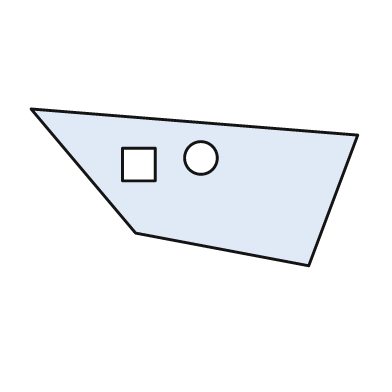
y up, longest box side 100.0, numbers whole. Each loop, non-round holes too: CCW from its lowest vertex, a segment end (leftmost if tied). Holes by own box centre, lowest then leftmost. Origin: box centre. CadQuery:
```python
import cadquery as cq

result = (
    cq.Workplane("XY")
    .moveTo(35.0, -24.0)
    .lineTo(50.0, 16.0)
    .lineTo(-50.0, 24.0)
    .lineTo(-18.0, -14.0)
    .close()
    .moveTo(-22.0, 2.0)
    .lineTo(-12.0, 2.0)
    .lineTo(-12.0, 12.0)
    .lineTo(-22.0, 12.0)
    .close()
    .moveTo(2.0, 9.0)
    .circle(5.0)
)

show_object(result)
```